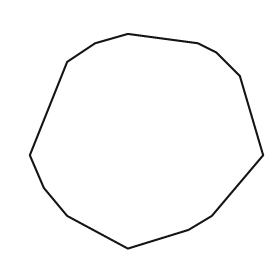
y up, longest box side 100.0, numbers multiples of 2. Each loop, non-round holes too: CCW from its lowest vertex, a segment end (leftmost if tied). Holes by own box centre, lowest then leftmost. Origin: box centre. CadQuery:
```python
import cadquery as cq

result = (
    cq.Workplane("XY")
    .moveTo(-8.0, -46.0)
    .lineTo(18.0, -38.0)
    .lineTo(28.0, -32.0)
    .lineTo(50.0, -6.0)
    .lineTo(40.0, 28.0)
    .lineTo(30.0, 38.0)
    .lineTo(22.0, 42.0)
    .lineTo(-8.0, 46.0)
    .lineTo(-22.0, 42.0)
    .lineTo(-34.0, 34.0)
    .lineTo(-50.0, -6.0)
    .lineTo(-44.0, -20.0)
    .lineTo(-34.0, -32.0)
    .close()
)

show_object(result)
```